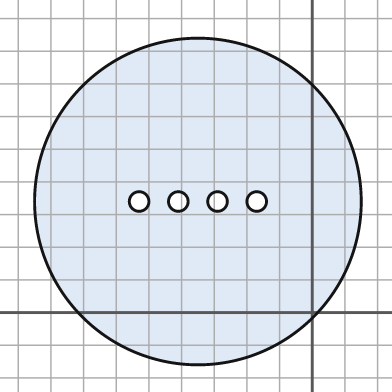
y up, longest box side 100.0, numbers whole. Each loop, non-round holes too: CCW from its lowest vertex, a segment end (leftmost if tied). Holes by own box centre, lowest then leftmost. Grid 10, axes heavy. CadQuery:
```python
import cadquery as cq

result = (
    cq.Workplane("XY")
    .moveTo(-35.0, 34.0)
    .circle(50.0)
    .moveTo(-53.0, 34.0)
    .circle(3.0)
    .moveTo(-41.0, 34.0)
    .circle(3.0)
    .moveTo(-29.0, 34.0)
    .circle(3.0)
    .moveTo(-17.0, 34.0)
    .circle(3.0)
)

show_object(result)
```